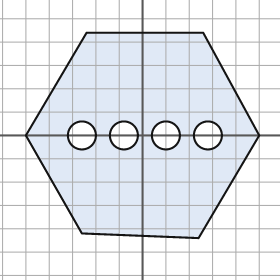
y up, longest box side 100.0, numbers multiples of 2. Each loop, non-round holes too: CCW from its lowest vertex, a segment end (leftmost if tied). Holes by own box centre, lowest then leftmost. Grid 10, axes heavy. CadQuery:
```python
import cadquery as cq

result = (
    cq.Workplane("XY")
    .moveTo(24.0, -44.0)
    .lineTo(50.0, 0.0)
    .lineTo(26.0, 44.0)
    .lineTo(-24.0, 44.0)
    .lineTo(-50.0, 0.0)
    .lineTo(-26.0, -42.0)
    .close()
    .moveTo(-26.0, 0.0)
    .circle(6.0)
    .moveTo(-8.0, 0.0)
    .circle(6.0)
    .moveTo(10.0, 0.0)
    .circle(6.0)
    .moveTo(28.0, 0.0)
    .circle(6.0)
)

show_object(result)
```